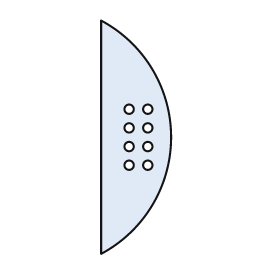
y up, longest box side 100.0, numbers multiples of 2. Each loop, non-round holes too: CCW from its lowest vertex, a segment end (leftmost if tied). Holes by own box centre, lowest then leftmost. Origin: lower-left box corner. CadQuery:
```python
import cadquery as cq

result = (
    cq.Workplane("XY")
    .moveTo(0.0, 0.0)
    .threePointArc((30.0, 50.0), (0.0, 100.0))
    .close()
    .moveTo(12.0, 38.0)
    .circle(2.0)
    .moveTo(20.0, 38.0)
    .circle(2.0)
    .moveTo(12.0, 46.0)
    .circle(2.0)
    .moveTo(20.0, 46.0)
    .circle(2.0)
    .moveTo(12.0, 54.0)
    .circle(2.0)
    .moveTo(20.0, 54.0)
    .circle(2.0)
    .moveTo(12.0, 62.0)
    .circle(2.0)
    .moveTo(20.0, 62.0)
    .circle(2.0)
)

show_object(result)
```